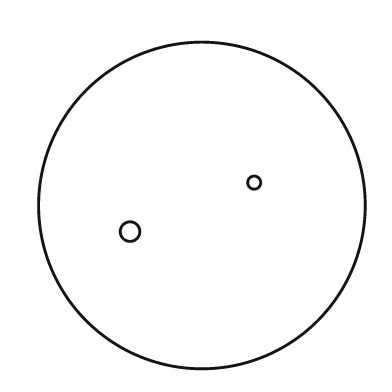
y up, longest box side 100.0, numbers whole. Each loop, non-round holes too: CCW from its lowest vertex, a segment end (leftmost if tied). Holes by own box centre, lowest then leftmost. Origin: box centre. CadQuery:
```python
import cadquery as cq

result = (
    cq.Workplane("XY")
    .moveTo(0.0, 0.0)
    .circle(50.0)
    .moveTo(-22.0, -8.0)
    .circle(3.0)
    .moveTo(16.0, 7.0)
    .circle(2.0)
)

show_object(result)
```